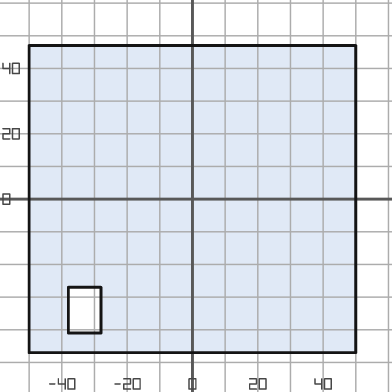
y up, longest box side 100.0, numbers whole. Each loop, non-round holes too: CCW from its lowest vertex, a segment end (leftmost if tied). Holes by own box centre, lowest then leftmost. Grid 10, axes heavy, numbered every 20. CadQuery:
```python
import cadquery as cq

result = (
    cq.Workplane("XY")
    .moveTo(-50.0, -47.0)
    .lineTo(50.0, -47.0)
    .lineTo(50.0, 47.0)
    .lineTo(-50.0, 47.0)
    .close()
    .moveTo(-38.0, -41.0)
    .lineTo(-28.0, -41.0)
    .lineTo(-28.0, -27.0)
    .lineTo(-38.0, -27.0)
    .close()
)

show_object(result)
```